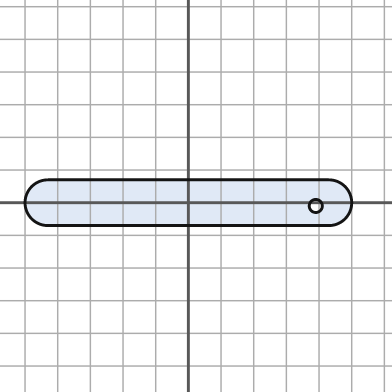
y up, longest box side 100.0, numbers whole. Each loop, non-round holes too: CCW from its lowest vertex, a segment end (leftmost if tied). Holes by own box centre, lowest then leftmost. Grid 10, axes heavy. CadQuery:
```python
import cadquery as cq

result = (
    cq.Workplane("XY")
    .moveTo(-43.0, -7.0)
    .lineTo(43.0, -7.0)
    .threePointArc((50.0, 0.0), (43.0, 7.0))
    .lineTo(-43.0, 7.0)
    .threePointArc((-50.0, 0.0), (-43.0, -7.0))
    .close()
    .moveTo(39.0, -1.0)
    .circle(2.0)
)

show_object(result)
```